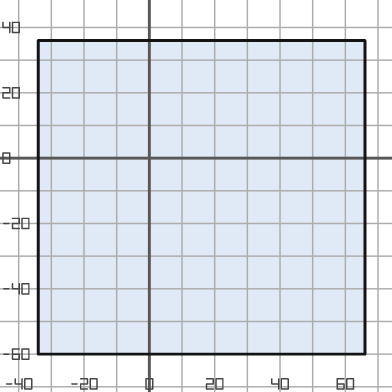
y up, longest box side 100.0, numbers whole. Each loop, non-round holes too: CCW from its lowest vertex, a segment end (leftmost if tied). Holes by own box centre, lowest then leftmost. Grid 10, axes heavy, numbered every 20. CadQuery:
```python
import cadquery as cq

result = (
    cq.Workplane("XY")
    .moveTo(-34.0, -60.0)
    .lineTo(66.0, -60.0)
    .lineTo(66.0, 36.0)
    .lineTo(-34.0, 36.0)
    .close()
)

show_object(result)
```